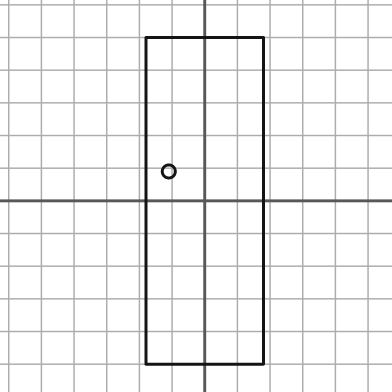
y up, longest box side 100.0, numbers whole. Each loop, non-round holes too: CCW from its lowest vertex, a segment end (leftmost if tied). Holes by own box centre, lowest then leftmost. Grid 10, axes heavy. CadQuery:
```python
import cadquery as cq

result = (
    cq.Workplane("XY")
    .moveTo(-18.0, -50.0)
    .lineTo(18.0, -50.0)
    .lineTo(18.0, 50.0)
    .lineTo(-18.0, 50.0)
    .close()
    .moveTo(-11.0, 9.0)
    .circle(2.0)
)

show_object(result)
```